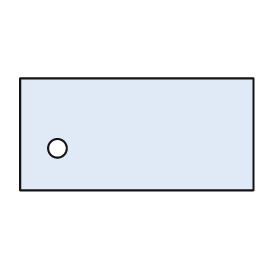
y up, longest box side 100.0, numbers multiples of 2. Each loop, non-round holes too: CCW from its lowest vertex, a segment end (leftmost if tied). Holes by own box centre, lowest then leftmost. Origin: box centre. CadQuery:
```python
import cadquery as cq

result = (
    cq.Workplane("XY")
    .moveTo(-50.0, -24.0)
    .lineTo(50.0, -24.0)
    .lineTo(50.0, 24.0)
    .lineTo(-50.0, 24.0)
    .close()
    .moveTo(-34.0, -6.0)
    .circle(4.0)
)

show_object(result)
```